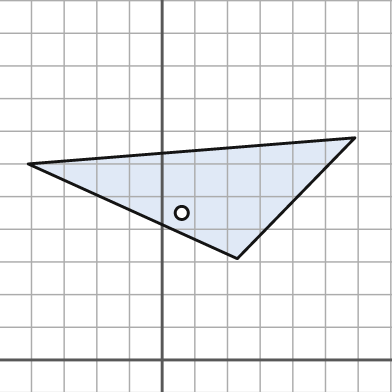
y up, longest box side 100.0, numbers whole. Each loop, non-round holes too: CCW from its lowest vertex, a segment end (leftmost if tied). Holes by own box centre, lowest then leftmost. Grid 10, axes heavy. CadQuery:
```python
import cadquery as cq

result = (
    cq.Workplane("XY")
    .moveTo(23.0, 31.0)
    .lineTo(59.0, 68.0)
    .lineTo(-41.0, 60.0)
    .close()
    .moveTo(6.0, 45.0)
    .circle(2.0)
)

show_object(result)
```